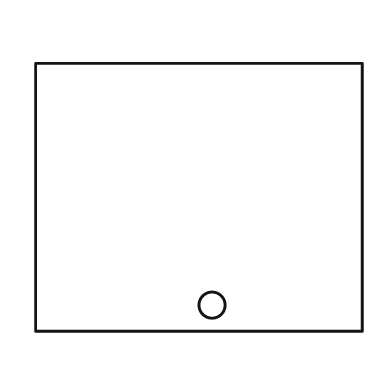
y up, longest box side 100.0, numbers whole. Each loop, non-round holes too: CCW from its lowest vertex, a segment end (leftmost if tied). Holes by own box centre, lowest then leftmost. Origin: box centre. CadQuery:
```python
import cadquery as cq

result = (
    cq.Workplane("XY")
    .moveTo(-50.0, -41.0)
    .lineTo(50.0, -41.0)
    .lineTo(50.0, 41.0)
    .lineTo(-50.0, 41.0)
    .close()
    .moveTo(4.0, -33.0)
    .circle(4.0)
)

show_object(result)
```